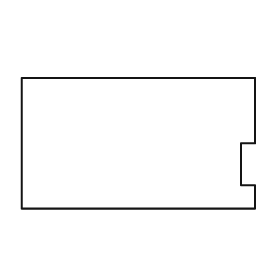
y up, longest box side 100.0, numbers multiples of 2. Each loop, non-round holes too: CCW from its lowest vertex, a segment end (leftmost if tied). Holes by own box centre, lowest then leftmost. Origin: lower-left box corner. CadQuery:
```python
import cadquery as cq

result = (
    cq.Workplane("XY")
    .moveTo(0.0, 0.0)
    .lineTo(100.0, 0.0)
    .lineTo(100.0, 10.0)
    .lineTo(94.0, 10.0)
    .lineTo(94.0, 28.0)
    .lineTo(100.0, 28.0)
    .lineTo(100.0, 56.0)
    .lineTo(0.0, 56.0)
    .close()
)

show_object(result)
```